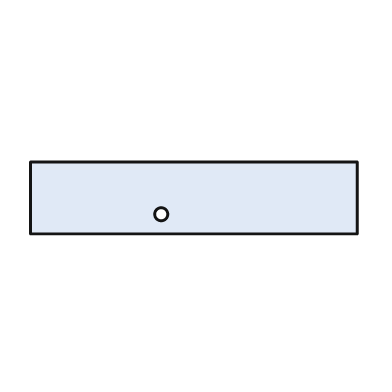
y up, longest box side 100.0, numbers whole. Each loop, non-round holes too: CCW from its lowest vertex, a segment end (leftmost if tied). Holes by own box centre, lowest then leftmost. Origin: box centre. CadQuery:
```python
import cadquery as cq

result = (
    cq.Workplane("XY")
    .moveTo(-50.0, -11.0)
    .lineTo(50.0, -11.0)
    .lineTo(50.0, 11.0)
    .lineTo(-50.0, 11.0)
    .close()
    .moveTo(-10.0, -5.0)
    .circle(2.0)
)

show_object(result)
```